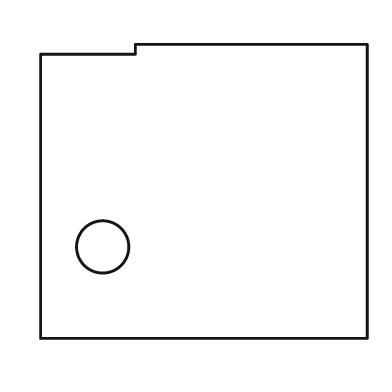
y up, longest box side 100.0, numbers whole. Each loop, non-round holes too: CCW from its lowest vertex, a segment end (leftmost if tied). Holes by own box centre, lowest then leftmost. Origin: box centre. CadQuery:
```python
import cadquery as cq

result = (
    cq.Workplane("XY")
    .moveTo(-50.0, -45.0)
    .lineTo(50.0, -45.0)
    .lineTo(50.0, 45.0)
    .lineTo(-21.0, 45.0)
    .lineTo(-21.0, 42.0)
    .lineTo(-50.0, 42.0)
    .close()
    .moveTo(-31.0, -17.0)
    .circle(8.0)
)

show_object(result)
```